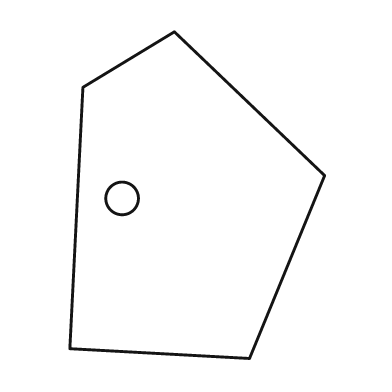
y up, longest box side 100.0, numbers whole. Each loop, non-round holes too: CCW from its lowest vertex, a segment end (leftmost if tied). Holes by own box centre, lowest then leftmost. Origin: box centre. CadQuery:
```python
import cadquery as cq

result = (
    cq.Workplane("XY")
    .moveTo(16.0, -50.0)
    .lineTo(39.0, 6.0)
    .lineTo(-7.0, 50.0)
    .lineTo(-35.0, 33.0)
    .lineTo(-39.0, -47.0)
    .close()
    .moveTo(-23.0, -1.0)
    .circle(5.0)
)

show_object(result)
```